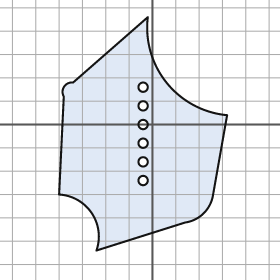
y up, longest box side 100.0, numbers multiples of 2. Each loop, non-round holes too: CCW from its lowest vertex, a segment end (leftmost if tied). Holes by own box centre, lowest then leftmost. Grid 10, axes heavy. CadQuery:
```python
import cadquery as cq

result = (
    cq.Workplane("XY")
    .moveTo(-24.0, -54.0)
    .lineTo(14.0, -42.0)
    .threePointArc((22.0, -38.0), (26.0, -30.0))
    .lineTo(32.0, 4.0)
    .threePointArc((6.0, 18.0), (-2.0, 46.0))
    .lineTo(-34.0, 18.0)
    .threePointArc((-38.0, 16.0), (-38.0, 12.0))
    .lineTo(-40.0, -30.0)
    .threePointArc((-26.0, -38.0), (-24.0, -54.0))
    .close()
    .moveTo(-4.0, -24.0)
    .circle(2.0)
    .moveTo(-4.0, -16.0)
    .circle(2.0)
    .moveTo(-4.0, -8.0)
    .circle(2.0)
    .moveTo(-4.0, 0.0)
    .circle(2.0)
    .moveTo(-4.0, 8.0)
    .circle(2.0)
    .moveTo(-4.0, 16.0)
    .circle(2.0)
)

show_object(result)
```